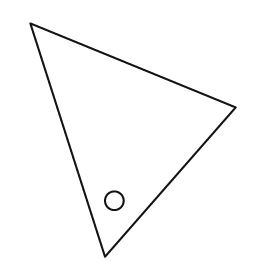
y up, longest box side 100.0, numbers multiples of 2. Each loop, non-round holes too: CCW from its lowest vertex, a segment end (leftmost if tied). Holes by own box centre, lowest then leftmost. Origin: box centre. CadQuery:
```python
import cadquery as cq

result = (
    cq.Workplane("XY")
    .moveTo(-12.0, -50.0)
    .lineTo(44.0, 14.0)
    .lineTo(-44.0, 50.0)
    .close()
    .moveTo(-8.0, -26.0)
    .circle(4.0)
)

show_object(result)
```